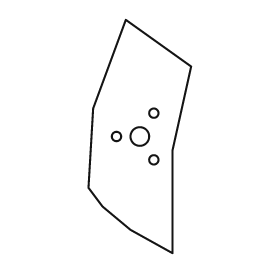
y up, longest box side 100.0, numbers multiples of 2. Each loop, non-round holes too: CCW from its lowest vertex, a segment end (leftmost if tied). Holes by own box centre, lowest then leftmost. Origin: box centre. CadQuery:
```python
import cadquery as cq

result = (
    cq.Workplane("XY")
    .moveTo(14.0, -50.0)
    .lineTo(14.0, -6.0)
    .lineTo(22.0, 30.0)
    .lineTo(-6.0, 50.0)
    .lineTo(-20.0, 12.0)
    .lineTo(-22.0, -22.0)
    .lineTo(-16.0, -30.0)
    .lineTo(-4.0, -40.0)
    .close()
    .moveTo(6.0, -10.0)
    .circle(2.0)
    .moveTo(-10.0, 0.0)
    .circle(2.0)
    .moveTo(0.0, 0.0)
    .circle(4.0)
    .moveTo(6.0, 10.0)
    .circle(2.0)
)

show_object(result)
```